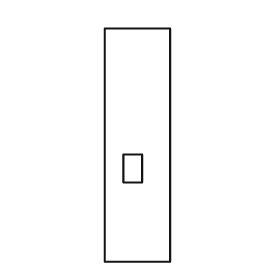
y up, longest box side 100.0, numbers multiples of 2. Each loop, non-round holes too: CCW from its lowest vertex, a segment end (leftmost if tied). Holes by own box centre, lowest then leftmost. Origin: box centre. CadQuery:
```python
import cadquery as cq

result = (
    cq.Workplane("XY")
    .moveTo(-14.0, -50.0)
    .lineTo(14.0, -50.0)
    .lineTo(14.0, 50.0)
    .lineTo(-14.0, 50.0)
    .close()
    .moveTo(-6.0, -16.0)
    .lineTo(2.0, -16.0)
    .lineTo(2.0, -4.0)
    .lineTo(-6.0, -4.0)
    .close()
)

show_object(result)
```